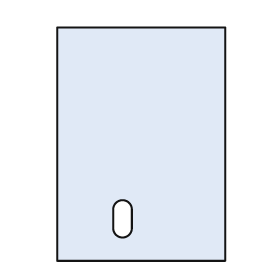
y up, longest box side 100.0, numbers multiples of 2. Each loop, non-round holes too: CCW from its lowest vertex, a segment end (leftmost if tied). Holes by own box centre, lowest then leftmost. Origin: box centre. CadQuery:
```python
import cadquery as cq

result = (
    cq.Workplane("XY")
    .moveTo(-36.0, -50.0)
    .lineTo(36.0, -50.0)
    .lineTo(36.0, 50.0)
    .lineTo(-36.0, 50.0)
    .close()
    .moveTo(-12.0, -36.0)
    .threePointArc((-8.0, -40.0), (-4.0, -36.0))
    .lineTo(-4.0, -28.0)
    .threePointArc((-8.0, -24.0), (-12.0, -28.0))
    .close()
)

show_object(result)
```